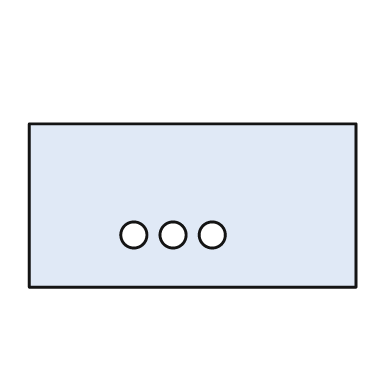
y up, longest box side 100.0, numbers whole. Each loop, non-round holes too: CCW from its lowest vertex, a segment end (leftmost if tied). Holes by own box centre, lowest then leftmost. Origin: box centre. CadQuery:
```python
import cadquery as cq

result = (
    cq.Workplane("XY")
    .moveTo(-50.0, -25.0)
    .lineTo(50.0, -25.0)
    .lineTo(50.0, 25.0)
    .lineTo(-50.0, 25.0)
    .close()
    .moveTo(-18.0, -9.0)
    .circle(4.0)
    .moveTo(-6.0, -9.0)
    .circle(4.0)
    .moveTo(6.0, -9.0)
    .circle(4.0)
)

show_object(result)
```